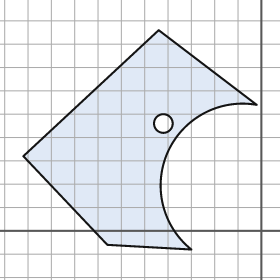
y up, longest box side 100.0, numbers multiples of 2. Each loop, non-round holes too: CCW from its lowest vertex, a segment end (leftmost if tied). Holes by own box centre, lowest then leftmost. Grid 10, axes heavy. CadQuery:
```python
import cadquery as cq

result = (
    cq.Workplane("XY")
    .moveTo(-30.0, -8.0)
    .threePointArc((-40.0, 34.0), (-2.0, 54.0))
    .lineTo(-44.0, 86.0)
    .lineTo(-102.0, 32.0)
    .lineTo(-66.0, -6.0)
    .close()
    .moveTo(-42.0, 46.0)
    .circle(4.0)
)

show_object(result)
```